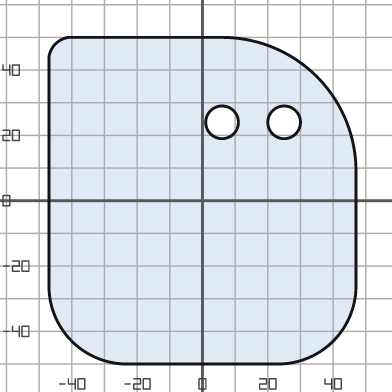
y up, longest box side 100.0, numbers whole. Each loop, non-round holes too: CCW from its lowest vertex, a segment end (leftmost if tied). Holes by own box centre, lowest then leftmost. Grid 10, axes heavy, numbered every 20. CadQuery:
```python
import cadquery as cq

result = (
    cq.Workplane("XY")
    .moveTo(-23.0, -50.0)
    .lineTo(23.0, -50.0)
    .threePointArc((40.0, -43.0), (47.0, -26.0))
    .lineTo(47.0, 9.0)
    .threePointArc((35.0, 38.0), (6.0, 50.0))
    .lineTo(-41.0, 50.0)
    .threePointArc((-45.0, 48.0), (-47.0, 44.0))
    .lineTo(-47.0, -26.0)
    .threePointArc((-40.0, -43.0), (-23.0, -50.0))
    .close()
    .moveTo(6.0, 24.0)
    .circle(5.0)
    .moveTo(25.0, 24.0)
    .circle(5.0)
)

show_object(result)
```